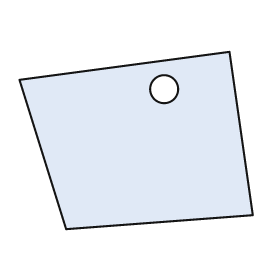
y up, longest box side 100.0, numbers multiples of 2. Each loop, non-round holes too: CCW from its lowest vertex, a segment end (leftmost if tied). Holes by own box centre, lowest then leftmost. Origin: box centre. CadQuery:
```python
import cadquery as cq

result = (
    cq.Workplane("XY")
    .moveTo(-30.0, -38.0)
    .lineTo(50.0, -32.0)
    .lineTo(40.0, 38.0)
    .lineTo(-50.0, 26.0)
    .close()
    .moveTo(12.0, 22.0)
    .circle(6.0)
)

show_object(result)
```